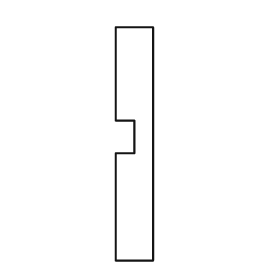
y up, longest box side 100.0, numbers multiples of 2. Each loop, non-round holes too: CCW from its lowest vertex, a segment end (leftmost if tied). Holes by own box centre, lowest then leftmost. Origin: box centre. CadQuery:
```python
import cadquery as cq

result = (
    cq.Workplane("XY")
    .moveTo(-8.0, -50.0)
    .lineTo(8.0, -50.0)
    .lineTo(8.0, 50.0)
    .lineTo(-8.0, 50.0)
    .lineTo(-8.0, 10.0)
    .lineTo(0.0, 10.0)
    .lineTo(0.0, -4.0)
    .lineTo(-8.0, -4.0)
    .close()
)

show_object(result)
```